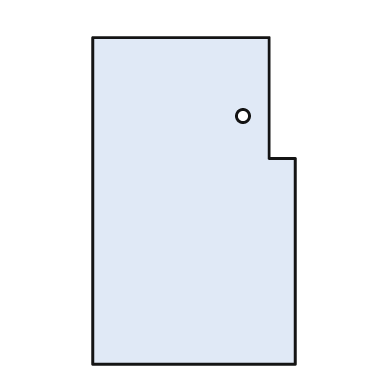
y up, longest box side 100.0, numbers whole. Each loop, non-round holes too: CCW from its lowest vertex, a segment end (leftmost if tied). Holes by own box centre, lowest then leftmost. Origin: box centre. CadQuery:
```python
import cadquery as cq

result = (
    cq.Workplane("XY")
    .moveTo(-31.0, -50.0)
    .lineTo(31.0, -50.0)
    .lineTo(31.0, 13.0)
    .lineTo(23.0, 13.0)
    .lineTo(23.0, 50.0)
    .lineTo(-31.0, 50.0)
    .close()
    .moveTo(15.0, 26.0)
    .circle(2.0)
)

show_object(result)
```